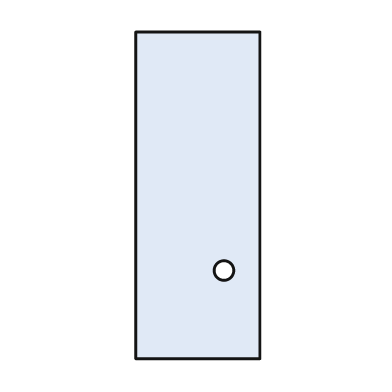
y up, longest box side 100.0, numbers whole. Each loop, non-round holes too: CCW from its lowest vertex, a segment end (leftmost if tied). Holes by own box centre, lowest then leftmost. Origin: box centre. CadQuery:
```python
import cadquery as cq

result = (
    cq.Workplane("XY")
    .moveTo(-19.0, -50.0)
    .lineTo(19.0, -50.0)
    .lineTo(19.0, 50.0)
    .lineTo(-19.0, 50.0)
    .close()
    .moveTo(8.0, -23.0)
    .circle(3.0)
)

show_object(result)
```